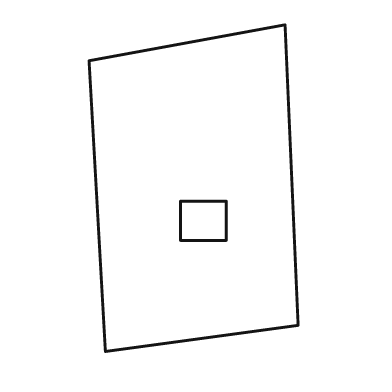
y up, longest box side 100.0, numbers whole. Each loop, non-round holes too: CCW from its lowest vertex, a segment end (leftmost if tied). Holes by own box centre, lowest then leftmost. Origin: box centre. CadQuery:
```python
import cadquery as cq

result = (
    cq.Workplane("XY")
    .moveTo(-27.0, -50.0)
    .lineTo(32.0, -42.0)
    .lineTo(28.0, 50.0)
    .lineTo(-32.0, 39.0)
    .close()
    .moveTo(-4.0, -16.0)
    .lineTo(10.0, -16.0)
    .lineTo(10.0, -4.0)
    .lineTo(-4.0, -4.0)
    .close()
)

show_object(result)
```